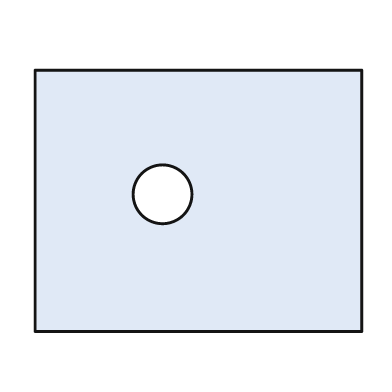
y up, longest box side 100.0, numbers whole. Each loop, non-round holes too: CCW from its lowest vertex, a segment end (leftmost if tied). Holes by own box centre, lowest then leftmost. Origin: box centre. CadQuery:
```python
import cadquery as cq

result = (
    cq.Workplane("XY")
    .moveTo(-50.0, -40.0)
    .lineTo(50.0, -40.0)
    .lineTo(50.0, 40.0)
    .lineTo(-50.0, 40.0)
    .close()
    .moveTo(-11.0, 2.0)
    .circle(9.0)
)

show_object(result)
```